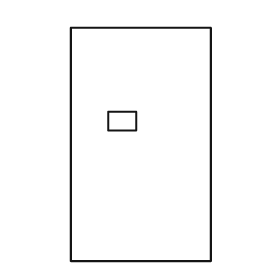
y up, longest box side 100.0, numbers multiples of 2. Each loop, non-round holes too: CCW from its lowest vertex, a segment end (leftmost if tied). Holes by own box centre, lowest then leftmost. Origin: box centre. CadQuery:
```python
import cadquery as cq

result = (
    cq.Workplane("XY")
    .moveTo(-30.0, -50.0)
    .lineTo(30.0, -50.0)
    .lineTo(30.0, 50.0)
    .lineTo(-30.0, 50.0)
    .close()
    .moveTo(-14.0, 6.0)
    .lineTo(-2.0, 6.0)
    .lineTo(-2.0, 14.0)
    .lineTo(-14.0, 14.0)
    .close()
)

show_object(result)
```